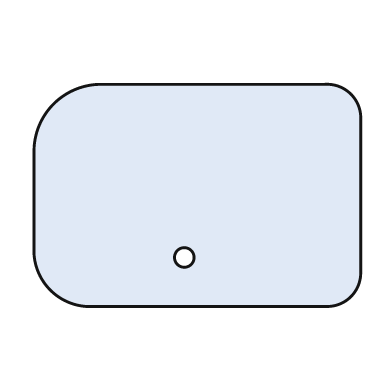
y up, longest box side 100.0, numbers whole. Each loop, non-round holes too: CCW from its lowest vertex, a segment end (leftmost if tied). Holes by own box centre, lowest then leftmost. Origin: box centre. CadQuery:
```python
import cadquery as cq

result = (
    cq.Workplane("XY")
    .moveTo(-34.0, -34.0)
    .lineTo(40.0, -34.0)
    .threePointArc((47.0, -31.0), (50.0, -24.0))
    .lineTo(50.0, 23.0)
    .threePointArc((47.0, 31.0), (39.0, 34.0))
    .lineTo(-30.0, 34.0)
    .threePointArc((-44.0, 28.0), (-50.0, 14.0))
    .lineTo(-50.0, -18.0)
    .threePointArc((-45.0, -29.0), (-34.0, -34.0))
    .close()
    .moveTo(-4.0, -19.0)
    .circle(3.0)
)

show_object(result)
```